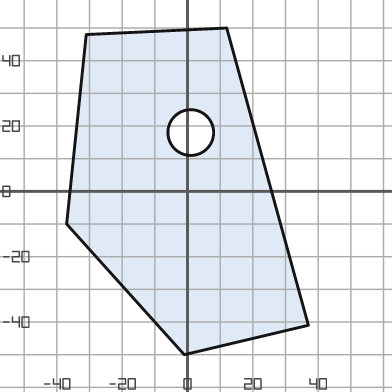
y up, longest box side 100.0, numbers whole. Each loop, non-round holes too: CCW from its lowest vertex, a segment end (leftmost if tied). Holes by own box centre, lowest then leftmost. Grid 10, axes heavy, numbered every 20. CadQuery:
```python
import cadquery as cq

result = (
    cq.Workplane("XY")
    .moveTo(-1.0, -50.0)
    .lineTo(37.0, -41.0)
    .lineTo(12.0, 50.0)
    .lineTo(-31.0, 48.0)
    .lineTo(-37.0, -10.0)
    .close()
    .moveTo(1.0, 18.0)
    .circle(7.0)
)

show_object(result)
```